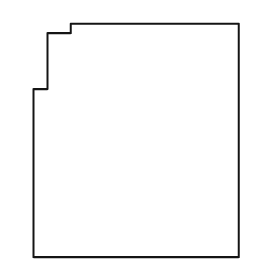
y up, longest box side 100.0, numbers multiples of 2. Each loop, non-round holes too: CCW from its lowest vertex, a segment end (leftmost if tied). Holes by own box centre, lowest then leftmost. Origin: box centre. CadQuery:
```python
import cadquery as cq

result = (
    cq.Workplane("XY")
    .moveTo(-44.0, -50.0)
    .lineTo(44.0, -50.0)
    .lineTo(44.0, 50.0)
    .lineTo(-28.0, 50.0)
    .lineTo(-28.0, 46.0)
    .lineTo(-38.0, 46.0)
    .lineTo(-38.0, 22.0)
    .lineTo(-44.0, 22.0)
    .close()
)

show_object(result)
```